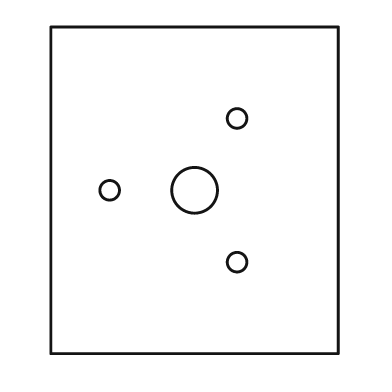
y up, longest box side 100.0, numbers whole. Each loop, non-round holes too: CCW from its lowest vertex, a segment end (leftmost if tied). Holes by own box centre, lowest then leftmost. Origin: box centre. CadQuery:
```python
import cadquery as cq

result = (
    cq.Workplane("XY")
    .moveTo(-44.0, -50.0)
    .lineTo(44.0, -50.0)
    .lineTo(44.0, 50.0)
    .lineTo(-44.0, 50.0)
    .close()
    .moveTo(13.0, -22.0)
    .circle(3.0)
    .moveTo(-26.0, 0.0)
    .circle(3.0)
    .moveTo(0.0, 0.0)
    .circle(7.0)
    .moveTo(13.0, 22.0)
    .circle(3.0)
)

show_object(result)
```